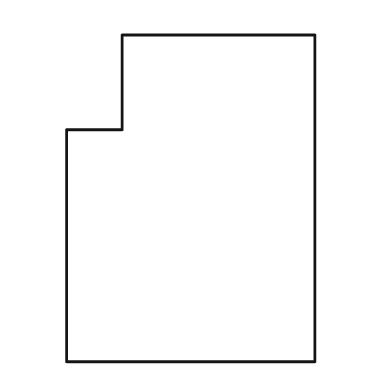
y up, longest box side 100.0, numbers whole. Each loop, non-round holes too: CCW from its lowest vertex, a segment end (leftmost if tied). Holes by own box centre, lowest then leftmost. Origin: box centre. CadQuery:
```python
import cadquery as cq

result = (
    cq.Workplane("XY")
    .moveTo(-38.0, -50.0)
    .lineTo(38.0, -50.0)
    .lineTo(38.0, 50.0)
    .lineTo(-21.0, 50.0)
    .lineTo(-21.0, 21.0)
    .lineTo(-38.0, 21.0)
    .close()
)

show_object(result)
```